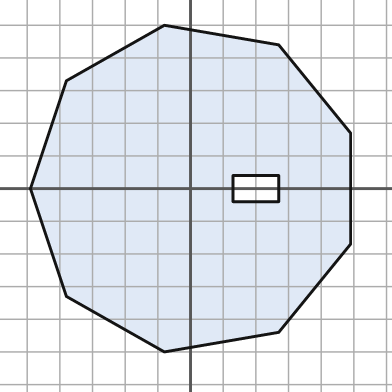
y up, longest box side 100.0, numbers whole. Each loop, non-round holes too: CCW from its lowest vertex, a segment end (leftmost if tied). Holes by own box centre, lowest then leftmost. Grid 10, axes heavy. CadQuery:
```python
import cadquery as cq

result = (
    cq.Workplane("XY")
    .moveTo(-8.0, -50.0)
    .lineTo(27.0, -44.0)
    .lineTo(49.0, -17.0)
    .lineTo(49.0, 17.0)
    .lineTo(27.0, 44.0)
    .lineTo(-8.0, 50.0)
    .lineTo(-38.0, 33.0)
    .lineTo(-49.0, 0.0)
    .lineTo(-38.0, -33.0)
    .close()
    .moveTo(13.0, -4.0)
    .lineTo(27.0, -4.0)
    .lineTo(27.0, 4.0)
    .lineTo(13.0, 4.0)
    .close()
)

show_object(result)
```